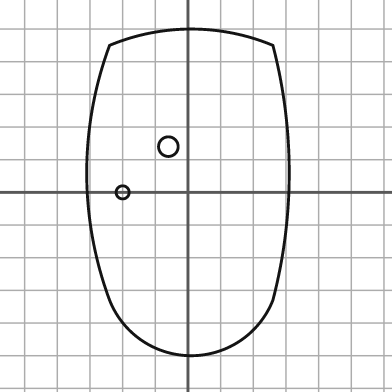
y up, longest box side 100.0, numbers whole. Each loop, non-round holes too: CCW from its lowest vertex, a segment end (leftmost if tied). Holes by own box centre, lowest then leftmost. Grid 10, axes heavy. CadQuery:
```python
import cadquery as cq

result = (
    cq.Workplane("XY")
    .moveTo(-24.0, -33.0)
    .threePointArc((1.0, -50.0), (26.0, -33.0))
    .threePointArc((31.0, 6.0), (26.0, 45.0))
    .threePointArc((1.0, 50.0), (-24.0, 45.0))
    .threePointArc((-31.0, 6.0), (-24.0, -33.0))
    .close()
    .moveTo(-20.0, 0.0)
    .circle(2.0)
    .moveTo(-6.0, 14.0)
    .circle(3.0)
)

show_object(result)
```